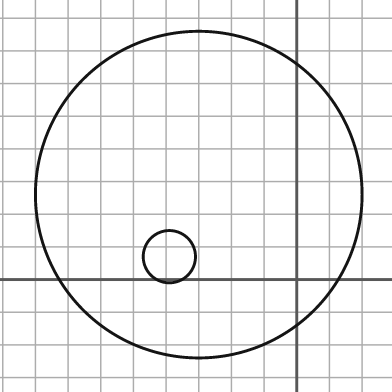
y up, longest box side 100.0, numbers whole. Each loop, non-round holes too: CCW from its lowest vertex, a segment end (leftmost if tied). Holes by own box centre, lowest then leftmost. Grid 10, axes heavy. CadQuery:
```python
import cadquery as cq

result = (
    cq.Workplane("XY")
    .moveTo(-30.0, 26.0)
    .circle(50.0)
    .moveTo(-39.0, 7.0)
    .circle(8.0)
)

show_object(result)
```